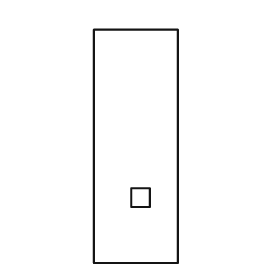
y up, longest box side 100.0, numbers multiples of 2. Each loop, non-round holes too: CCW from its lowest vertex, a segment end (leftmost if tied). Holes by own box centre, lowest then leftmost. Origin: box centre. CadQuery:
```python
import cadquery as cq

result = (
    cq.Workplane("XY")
    .moveTo(-18.0, -50.0)
    .lineTo(18.0, -50.0)
    .lineTo(18.0, 50.0)
    .lineTo(-18.0, 50.0)
    .close()
    .moveTo(-2.0, -26.0)
    .lineTo(6.0, -26.0)
    .lineTo(6.0, -18.0)
    .lineTo(-2.0, -18.0)
    .close()
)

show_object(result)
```